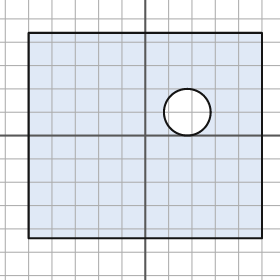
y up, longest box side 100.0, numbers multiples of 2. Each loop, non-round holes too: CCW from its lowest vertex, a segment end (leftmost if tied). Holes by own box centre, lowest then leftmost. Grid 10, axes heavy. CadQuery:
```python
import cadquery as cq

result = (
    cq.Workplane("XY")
    .moveTo(-50.0, -44.0)
    .lineTo(50.0, -44.0)
    .lineTo(50.0, 44.0)
    .lineTo(-50.0, 44.0)
    .close()
    .moveTo(18.0, 10.0)
    .circle(10.0)
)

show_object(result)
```